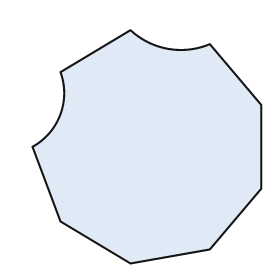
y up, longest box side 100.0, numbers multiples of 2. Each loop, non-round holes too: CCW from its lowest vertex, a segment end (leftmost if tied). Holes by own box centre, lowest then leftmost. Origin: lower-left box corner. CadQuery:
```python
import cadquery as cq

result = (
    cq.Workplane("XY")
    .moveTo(42.0, 0.0)
    .lineTo(76.0, 6.0)
    .lineTo(98.0, 32.0)
    .lineTo(98.0, 68.0)
    .lineTo(76.0, 94.0)
    .threePointArc((58.0, 92.0), (42.0, 100.0))
    .lineTo(12.0, 82.0)
    .threePointArc((12.0, 64.0), (0.0, 50.0))
    .lineTo(12.0, 18.0)
    .close()
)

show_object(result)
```